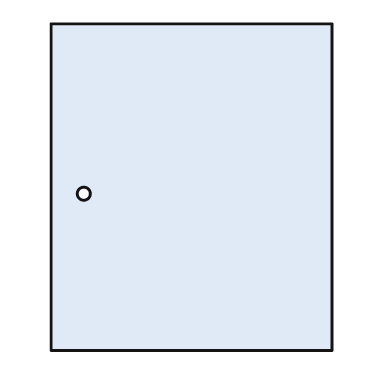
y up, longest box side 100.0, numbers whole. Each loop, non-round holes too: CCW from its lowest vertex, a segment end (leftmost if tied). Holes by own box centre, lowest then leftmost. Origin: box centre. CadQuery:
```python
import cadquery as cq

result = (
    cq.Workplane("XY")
    .moveTo(-43.0, -50.0)
    .lineTo(43.0, -50.0)
    .lineTo(43.0, 50.0)
    .lineTo(-43.0, 50.0)
    .close()
    .moveTo(-33.0, -2.0)
    .circle(2.0)
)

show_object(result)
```